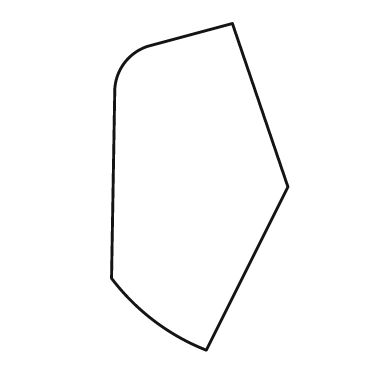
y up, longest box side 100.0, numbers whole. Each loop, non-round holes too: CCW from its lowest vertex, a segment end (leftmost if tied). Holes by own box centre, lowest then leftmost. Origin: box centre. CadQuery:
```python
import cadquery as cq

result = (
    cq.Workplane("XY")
    .moveTo(2.0, -50.0)
    .lineTo(27.0, 0.0)
    .lineTo(10.0, 50.0)
    .lineTo(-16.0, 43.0)
    .threePointArc((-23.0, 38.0), (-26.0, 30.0))
    .lineTo(-27.0, -28.0)
    .threePointArc((-14.0, -41.0), (2.0, -50.0))
    .close()
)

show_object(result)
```